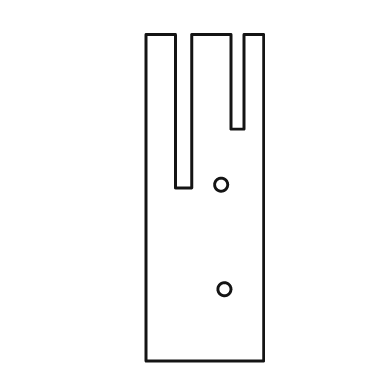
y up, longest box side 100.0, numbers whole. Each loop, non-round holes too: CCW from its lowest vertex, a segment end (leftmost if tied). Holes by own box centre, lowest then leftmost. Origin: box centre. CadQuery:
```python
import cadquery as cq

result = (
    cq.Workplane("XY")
    .moveTo(-18.0, -50.0)
    .lineTo(18.0, -50.0)
    .lineTo(18.0, 50.0)
    .lineTo(12.0, 50.0)
    .lineTo(12.0, 21.0)
    .lineTo(8.0, 21.0)
    .lineTo(8.0, 50.0)
    .lineTo(-4.0, 50.0)
    .lineTo(-4.0, 3.0)
    .lineTo(-9.0, 3.0)
    .lineTo(-9.0, 50.0)
    .lineTo(-18.0, 50.0)
    .close()
    .moveTo(6.0, -28.0)
    .circle(2.0)
    .moveTo(5.0, 4.0)
    .circle(2.0)
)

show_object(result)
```